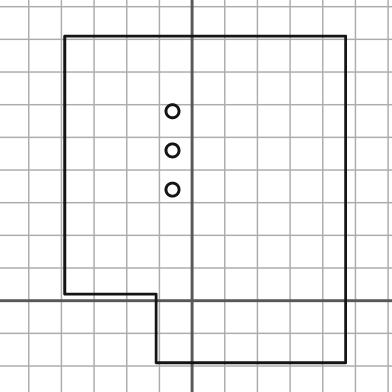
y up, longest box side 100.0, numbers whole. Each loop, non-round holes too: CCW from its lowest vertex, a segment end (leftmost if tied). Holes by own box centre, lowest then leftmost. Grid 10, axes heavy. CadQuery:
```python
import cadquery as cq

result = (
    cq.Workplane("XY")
    .moveTo(-11.0, -19.0)
    .lineTo(47.0, -19.0)
    .lineTo(47.0, 81.0)
    .lineTo(-39.0, 81.0)
    .lineTo(-39.0, 2.0)
    .lineTo(-11.0, 2.0)
    .close()
    .moveTo(-6.0, 34.0)
    .circle(2.0)
    .moveTo(-6.0, 46.0)
    .circle(2.0)
    .moveTo(-6.0, 58.0)
    .circle(2.0)
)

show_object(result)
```